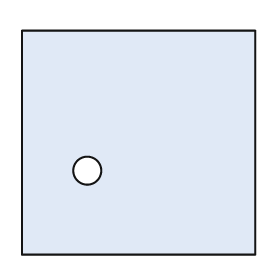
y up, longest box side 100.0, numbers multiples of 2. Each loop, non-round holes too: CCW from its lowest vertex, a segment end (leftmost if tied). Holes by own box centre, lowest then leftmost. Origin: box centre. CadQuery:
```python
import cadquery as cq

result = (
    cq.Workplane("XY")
    .moveTo(-50.0, -48.0)
    .lineTo(50.0, -48.0)
    .lineTo(50.0, 48.0)
    .lineTo(-50.0, 48.0)
    .close()
    .moveTo(-22.0, -12.0)
    .circle(6.0)
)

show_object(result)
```